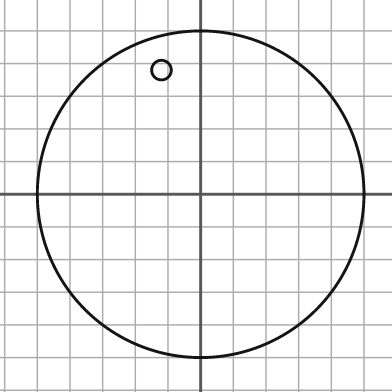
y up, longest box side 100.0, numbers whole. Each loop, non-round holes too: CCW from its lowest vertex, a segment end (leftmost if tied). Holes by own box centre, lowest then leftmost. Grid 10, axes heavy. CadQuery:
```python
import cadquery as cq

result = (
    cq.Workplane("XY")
    .moveTo(0.0, 0.0)
    .circle(50.0)
    .moveTo(-12.0, 38.0)
    .circle(3.0)
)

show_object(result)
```